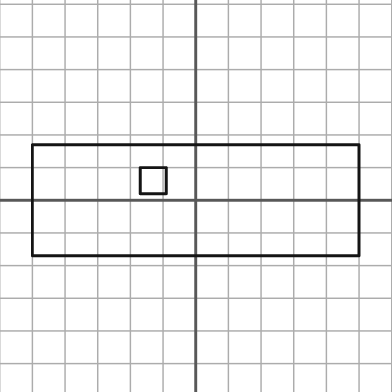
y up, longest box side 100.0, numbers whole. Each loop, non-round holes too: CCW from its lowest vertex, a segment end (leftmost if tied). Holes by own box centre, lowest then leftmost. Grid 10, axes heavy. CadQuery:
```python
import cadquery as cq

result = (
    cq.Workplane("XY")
    .moveTo(-50.0, -17.0)
    .lineTo(50.0, -17.0)
    .lineTo(50.0, 17.0)
    .lineTo(-50.0, 17.0)
    .close()
    .moveTo(-17.0, 2.0)
    .lineTo(-9.0, 2.0)
    .lineTo(-9.0, 10.0)
    .lineTo(-17.0, 10.0)
    .close()
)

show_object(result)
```